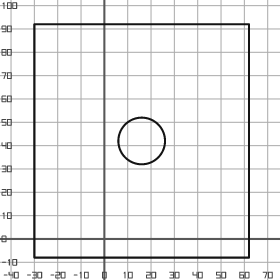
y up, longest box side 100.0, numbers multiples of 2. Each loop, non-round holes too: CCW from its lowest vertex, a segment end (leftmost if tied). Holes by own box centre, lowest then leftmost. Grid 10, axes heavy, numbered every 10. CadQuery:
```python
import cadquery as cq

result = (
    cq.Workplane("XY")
    .moveTo(-30.0, -8.0)
    .lineTo(62.0, -8.0)
    .lineTo(62.0, 92.0)
    .lineTo(-30.0, 92.0)
    .close()
    .moveTo(16.0, 42.0)
    .circle(10.0)
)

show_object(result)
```